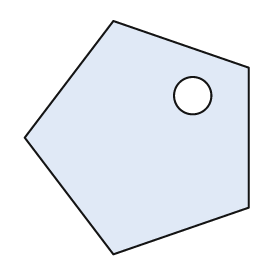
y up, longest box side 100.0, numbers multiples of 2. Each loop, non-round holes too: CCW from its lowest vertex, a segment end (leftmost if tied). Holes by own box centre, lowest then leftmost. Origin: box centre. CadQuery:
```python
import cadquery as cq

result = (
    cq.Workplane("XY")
    .moveTo(-10.0, -50.0)
    .lineTo(48.0, -30.0)
    .lineTo(48.0, 30.0)
    .lineTo(-10.0, 50.0)
    .lineTo(-48.0, 0.0)
    .close()
    .moveTo(24.0, 18.0)
    .circle(8.0)
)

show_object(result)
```